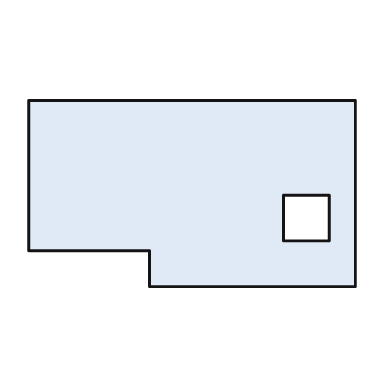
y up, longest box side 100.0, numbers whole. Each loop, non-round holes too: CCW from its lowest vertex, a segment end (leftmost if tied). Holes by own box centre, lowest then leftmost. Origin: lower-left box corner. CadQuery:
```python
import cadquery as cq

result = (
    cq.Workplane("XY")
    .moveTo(37.0, 0.0)
    .lineTo(100.0, 0.0)
    .lineTo(100.0, 57.0)
    .lineTo(0.0, 57.0)
    .lineTo(0.0, 11.0)
    .lineTo(37.0, 11.0)
    .close()
    .moveTo(78.0, 14.0)
    .lineTo(92.0, 14.0)
    .lineTo(92.0, 28.0)
    .lineTo(78.0, 28.0)
    .close()
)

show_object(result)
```